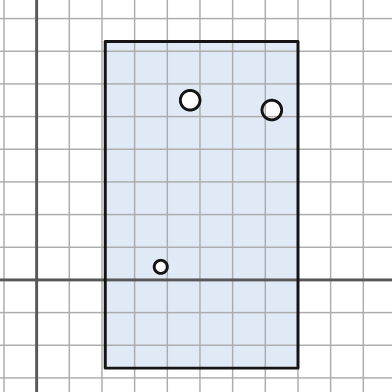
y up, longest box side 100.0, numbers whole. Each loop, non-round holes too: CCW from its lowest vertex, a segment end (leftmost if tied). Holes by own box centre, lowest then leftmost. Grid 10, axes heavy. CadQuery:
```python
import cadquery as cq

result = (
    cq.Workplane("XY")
    .moveTo(21.0, -27.0)
    .lineTo(80.0, -27.0)
    .lineTo(80.0, 73.0)
    .lineTo(21.0, 73.0)
    .close()
    .moveTo(38.0, 4.0)
    .circle(2.0)
    .moveTo(72.0, 52.0)
    .circle(3.0)
    .moveTo(47.0, 55.0)
    .circle(3.0)
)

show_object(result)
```